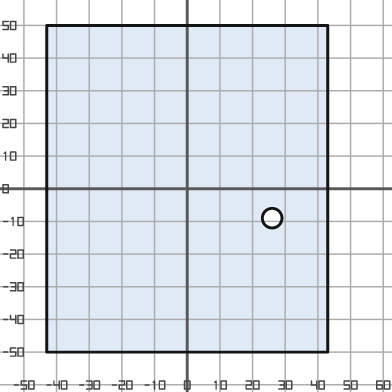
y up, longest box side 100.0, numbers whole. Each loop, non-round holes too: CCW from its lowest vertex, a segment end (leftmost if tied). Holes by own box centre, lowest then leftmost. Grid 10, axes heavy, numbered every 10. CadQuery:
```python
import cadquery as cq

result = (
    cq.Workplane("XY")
    .moveTo(-43.0, -50.0)
    .lineTo(43.0, -50.0)
    .lineTo(43.0, 50.0)
    .lineTo(-43.0, 50.0)
    .close()
    .moveTo(26.0, -9.0)
    .circle(3.0)
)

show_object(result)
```